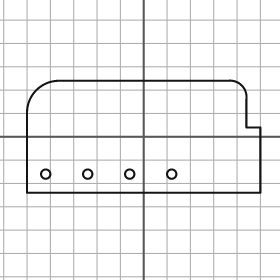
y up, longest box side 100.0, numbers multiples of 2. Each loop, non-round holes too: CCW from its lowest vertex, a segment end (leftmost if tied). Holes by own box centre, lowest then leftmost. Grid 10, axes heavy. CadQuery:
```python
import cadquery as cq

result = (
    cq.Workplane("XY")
    .moveTo(-50.0, -24.0)
    .lineTo(50.0, -24.0)
    .lineTo(50.0, 4.0)
    .lineTo(44.0, 4.0)
    .lineTo(44.0, 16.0)
    .threePointArc((42.0, 22.0), (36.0, 24.0))
    .lineTo(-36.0, 24.0)
    .threePointArc((-46.0, 20.0), (-50.0, 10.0))
    .close()
    .moveTo(-42.0, -16.0)
    .circle(2.0)
    .moveTo(-24.0, -16.0)
    .circle(2.0)
    .moveTo(-6.0, -16.0)
    .circle(2.0)
    .moveTo(12.0, -16.0)
    .circle(2.0)
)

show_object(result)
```